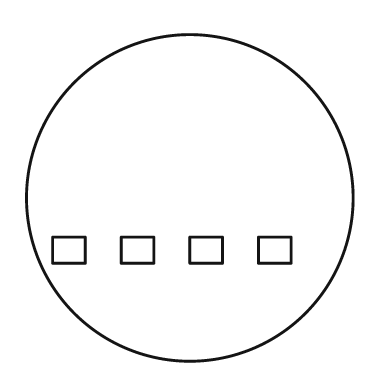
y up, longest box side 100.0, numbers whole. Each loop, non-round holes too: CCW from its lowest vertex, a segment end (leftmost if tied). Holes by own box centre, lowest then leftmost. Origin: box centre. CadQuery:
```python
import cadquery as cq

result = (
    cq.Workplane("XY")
    .moveTo(0.0, 0.0)
    .circle(50.0)
    .moveTo(-42.0, -20.0)
    .lineTo(-32.0, -20.0)
    .lineTo(-32.0, -12.0)
    .lineTo(-42.0, -12.0)
    .close()
    .moveTo(-21.0, -20.0)
    .lineTo(-11.0, -20.0)
    .lineTo(-11.0, -12.0)
    .lineTo(-21.0, -12.0)
    .close()
    .moveTo(0.0, -20.0)
    .lineTo(10.0, -20.0)
    .lineTo(10.0, -12.0)
    .lineTo(0.0, -12.0)
    .close()
    .moveTo(21.0, -20.0)
    .lineTo(31.0, -20.0)
    .lineTo(31.0, -12.0)
    .lineTo(21.0, -12.0)
    .close()
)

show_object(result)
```